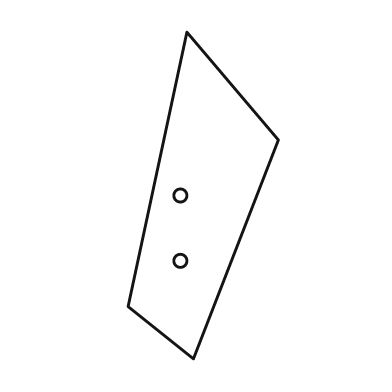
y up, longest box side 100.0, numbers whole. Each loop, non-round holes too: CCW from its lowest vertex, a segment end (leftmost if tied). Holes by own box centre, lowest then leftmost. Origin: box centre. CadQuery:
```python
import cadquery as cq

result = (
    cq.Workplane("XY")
    .moveTo(-3.0, -50.0)
    .lineTo(23.0, 17.0)
    .lineTo(-5.0, 50.0)
    .lineTo(-23.0, -34.0)
    .close()
    .moveTo(-7.0, -20.0)
    .circle(2.0)
    .moveTo(-7.0, 0.0)
    .circle(2.0)
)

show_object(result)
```